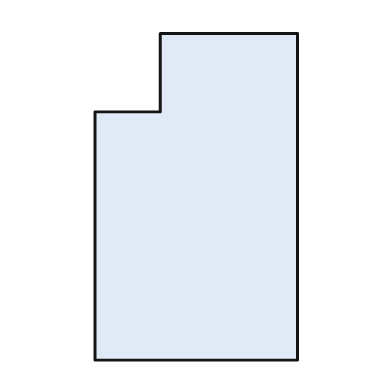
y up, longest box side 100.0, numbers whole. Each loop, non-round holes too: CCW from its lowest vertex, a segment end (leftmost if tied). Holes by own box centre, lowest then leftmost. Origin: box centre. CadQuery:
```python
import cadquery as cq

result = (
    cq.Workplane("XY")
    .moveTo(-31.0, -50.0)
    .lineTo(31.0, -50.0)
    .lineTo(31.0, 50.0)
    .lineTo(-11.0, 50.0)
    .lineTo(-11.0, 26.0)
    .lineTo(-31.0, 26.0)
    .close()
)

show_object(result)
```